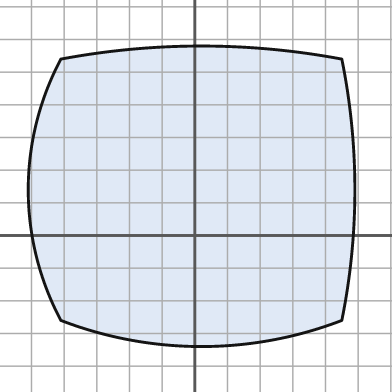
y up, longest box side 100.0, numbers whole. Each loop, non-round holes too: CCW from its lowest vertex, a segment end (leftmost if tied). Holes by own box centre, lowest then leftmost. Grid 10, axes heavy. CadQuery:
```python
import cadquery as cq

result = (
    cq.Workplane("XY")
    .moveTo(-41.0, -26.0)
    .threePointArc((2.0, -34.0), (45.0, -26.0))
    .threePointArc((49.0, 14.0), (45.0, 54.0))
    .threePointArc((2.0, 58.0), (-41.0, 54.0))
    .threePointArc((-51.0, 14.0), (-41.0, -26.0))
    .close()
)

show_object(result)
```